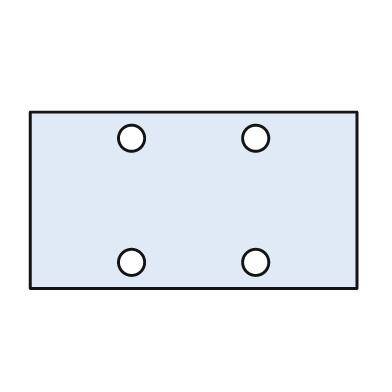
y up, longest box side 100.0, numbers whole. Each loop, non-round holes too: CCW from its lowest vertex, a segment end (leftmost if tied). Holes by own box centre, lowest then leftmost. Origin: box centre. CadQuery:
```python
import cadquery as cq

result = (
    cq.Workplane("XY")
    .moveTo(-50.0, -27.0)
    .lineTo(50.0, -27.0)
    .lineTo(50.0, 27.0)
    .lineTo(-50.0, 27.0)
    .close()
    .moveTo(-19.0, -19.0)
    .circle(4.0)
    .moveTo(19.0, -19.0)
    .circle(4.0)
    .moveTo(-19.0, 19.0)
    .circle(4.0)
    .moveTo(19.0, 19.0)
    .circle(4.0)
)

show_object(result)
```